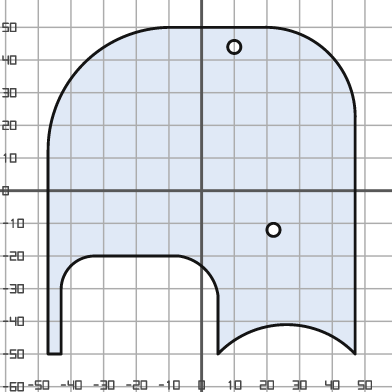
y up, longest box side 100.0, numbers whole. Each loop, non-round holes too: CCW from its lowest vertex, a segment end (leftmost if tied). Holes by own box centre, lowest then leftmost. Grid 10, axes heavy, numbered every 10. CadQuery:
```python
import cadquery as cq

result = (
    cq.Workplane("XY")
    .moveTo(-47.0, -50.0)
    .lineTo(-43.0, -50.0)
    .lineTo(-43.0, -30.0)
    .threePointArc((-40.0, -23.0), (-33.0, -20.0))
    .lineTo(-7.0, -20.0)
    .threePointArc((1.0, -24.0), (5.0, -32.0))
    .lineTo(5.0, -50.0)
    .threePointArc((26.0, -41.0), (47.0, -50.0))
    .lineTo(47.0, 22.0)
    .threePointArc((39.0, 42.0), (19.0, 50.0))
    .lineTo(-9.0, 50.0)
    .threePointArc((-36.0, 39.0), (-47.0, 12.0))
    .close()
    .moveTo(22.0, -12.0)
    .circle(2.0)
    .moveTo(10.0, 44.0)
    .circle(2.0)
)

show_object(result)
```